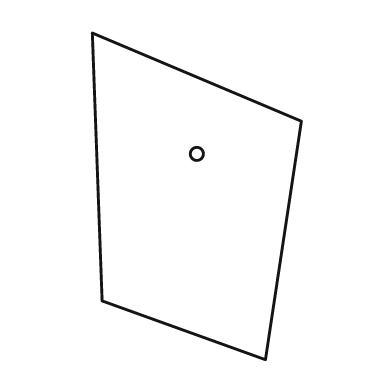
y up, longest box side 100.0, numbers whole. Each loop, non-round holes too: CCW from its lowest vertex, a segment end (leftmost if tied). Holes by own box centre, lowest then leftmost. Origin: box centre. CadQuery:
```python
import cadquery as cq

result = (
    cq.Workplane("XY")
    .moveTo(21.0, -50.0)
    .lineTo(32.0, 23.0)
    .lineTo(-32.0, 50.0)
    .lineTo(-29.0, -32.0)
    .close()
    .moveTo(0.0, 13.0)
    .circle(2.0)
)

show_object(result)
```